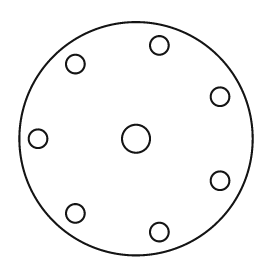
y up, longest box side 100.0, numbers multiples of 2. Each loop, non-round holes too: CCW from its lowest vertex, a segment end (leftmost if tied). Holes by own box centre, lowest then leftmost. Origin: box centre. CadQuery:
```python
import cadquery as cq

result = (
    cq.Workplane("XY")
    .moveTo(0.0, 0.0)
    .circle(50.0)
    .moveTo(10.0, -40.0)
    .circle(4.0)
    .moveTo(-26.0, -32.0)
    .circle(4.0)
    .moveTo(36.0, -18.0)
    .circle(4.0)
    .moveTo(-42.0, 0.0)
    .circle(4.0)
    .moveTo(0.0, 0.0)
    .circle(6.0)
    .moveTo(36.0, 18.0)
    .circle(4.0)
    .moveTo(-26.0, 32.0)
    .circle(4.0)
    .moveTo(10.0, 40.0)
    .circle(4.0)
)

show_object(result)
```